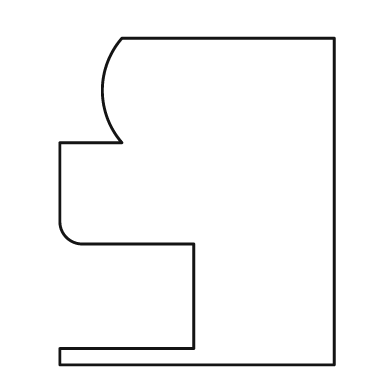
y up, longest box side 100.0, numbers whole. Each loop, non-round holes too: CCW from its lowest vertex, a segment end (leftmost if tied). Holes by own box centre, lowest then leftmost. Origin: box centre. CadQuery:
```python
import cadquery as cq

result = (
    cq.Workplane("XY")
    .moveTo(-42.0, -50.0)
    .lineTo(42.0, -50.0)
    .lineTo(42.0, 50.0)
    .lineTo(-23.0, 50.0)
    .threePointArc((-29.0, 34.0), (-23.0, 18.0))
    .lineTo(-42.0, 18.0)
    .lineTo(-42.0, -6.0)
    .threePointArc((-40.0, -11.0), (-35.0, -13.0))
    .lineTo(-1.0, -13.0)
    .lineTo(-1.0, -45.0)
    .lineTo(-42.0, -45.0)
    .close()
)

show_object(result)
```